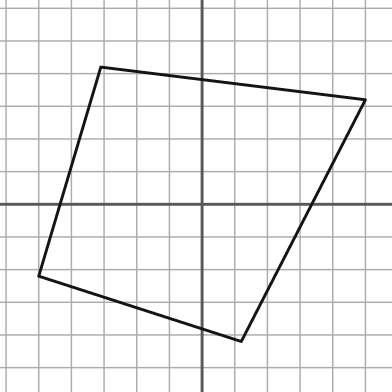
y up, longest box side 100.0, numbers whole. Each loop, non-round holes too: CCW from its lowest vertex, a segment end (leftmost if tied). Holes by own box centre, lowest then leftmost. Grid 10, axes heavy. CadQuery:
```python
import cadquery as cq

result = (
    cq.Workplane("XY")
    .moveTo(12.0, -42.0)
    .lineTo(50.0, 32.0)
    .lineTo(-31.0, 42.0)
    .lineTo(-50.0, -22.0)
    .close()
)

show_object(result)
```